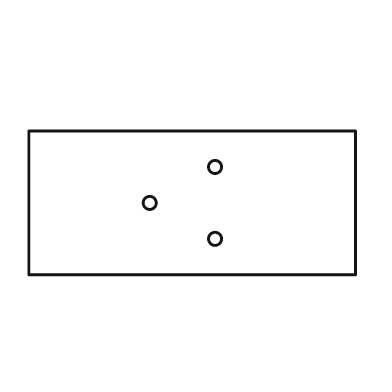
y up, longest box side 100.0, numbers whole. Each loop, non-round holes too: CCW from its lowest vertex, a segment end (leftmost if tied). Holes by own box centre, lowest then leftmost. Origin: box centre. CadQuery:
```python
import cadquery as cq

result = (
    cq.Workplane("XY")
    .moveTo(-50.0, -22.0)
    .lineTo(50.0, -22.0)
    .lineTo(50.0, 22.0)
    .lineTo(-50.0, 22.0)
    .close()
    .moveTo(7.0, -11.0)
    .circle(2.0)
    .moveTo(-13.0, 0.0)
    .circle(2.0)
    .moveTo(7.0, 11.0)
    .circle(2.0)
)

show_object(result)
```